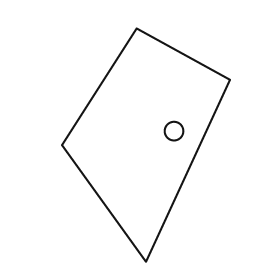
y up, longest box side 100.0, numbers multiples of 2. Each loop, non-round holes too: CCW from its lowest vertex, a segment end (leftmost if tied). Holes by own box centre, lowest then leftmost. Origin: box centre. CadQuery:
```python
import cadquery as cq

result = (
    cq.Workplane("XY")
    .moveTo(0.0, -50.0)
    .lineTo(36.0, 28.0)
    .lineTo(-4.0, 50.0)
    .lineTo(-36.0, 0.0)
    .close()
    .moveTo(12.0, 6.0)
    .circle(4.0)
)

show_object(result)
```